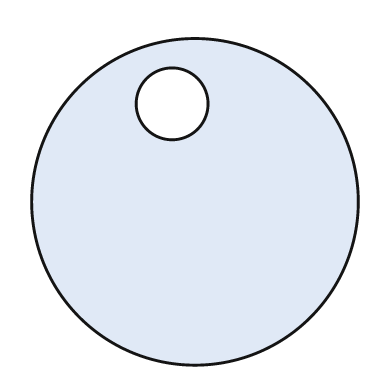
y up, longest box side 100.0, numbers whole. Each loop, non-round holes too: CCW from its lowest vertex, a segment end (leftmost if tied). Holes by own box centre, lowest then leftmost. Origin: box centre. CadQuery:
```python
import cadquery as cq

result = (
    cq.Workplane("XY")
    .moveTo(0.0, 0.0)
    .circle(50.0)
    .moveTo(-7.0, 30.0)
    .circle(11.0)
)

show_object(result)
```